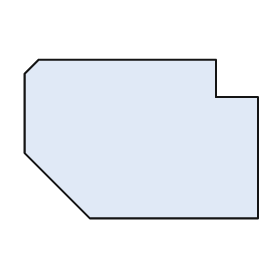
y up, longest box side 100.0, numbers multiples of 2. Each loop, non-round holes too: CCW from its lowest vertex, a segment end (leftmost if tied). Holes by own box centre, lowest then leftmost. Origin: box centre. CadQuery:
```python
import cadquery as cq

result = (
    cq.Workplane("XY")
    .moveTo(-22.0, -34.0)
    .lineTo(50.0, -34.0)
    .lineTo(50.0, 18.0)
    .lineTo(32.0, 18.0)
    .lineTo(32.0, 34.0)
    .lineTo(-44.0, 34.0)
    .lineTo(-50.0, 28.0)
    .lineTo(-50.0, -6.0)
    .close()
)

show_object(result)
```